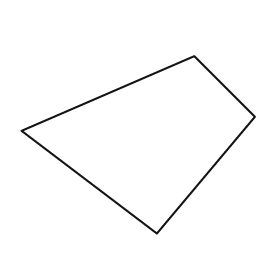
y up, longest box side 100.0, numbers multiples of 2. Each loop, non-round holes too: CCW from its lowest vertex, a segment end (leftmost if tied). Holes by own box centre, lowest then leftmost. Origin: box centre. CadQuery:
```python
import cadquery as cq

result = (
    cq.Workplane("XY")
    .moveTo(8.0, -38.0)
    .lineTo(50.0, 12.0)
    .lineTo(24.0, 38.0)
    .lineTo(-50.0, 6.0)
    .close()
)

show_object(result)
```